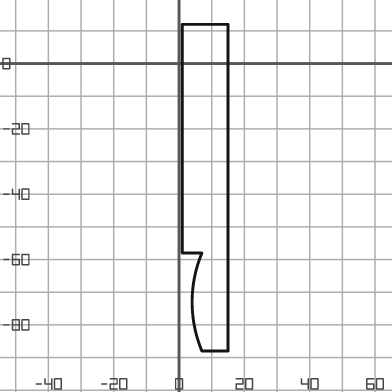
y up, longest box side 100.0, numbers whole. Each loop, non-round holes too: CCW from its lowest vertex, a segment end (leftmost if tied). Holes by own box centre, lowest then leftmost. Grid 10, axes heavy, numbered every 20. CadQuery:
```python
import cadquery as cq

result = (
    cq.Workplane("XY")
    .moveTo(7.0, -88.0)
    .lineTo(15.0, -88.0)
    .lineTo(15.0, 12.0)
    .lineTo(1.0, 12.0)
    .lineTo(1.0, -58.0)
    .lineTo(7.0, -58.0)
    .threePointArc((4.0, -73.0), (7.0, -88.0))
    .close()
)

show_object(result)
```